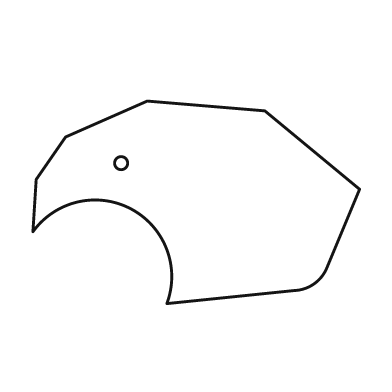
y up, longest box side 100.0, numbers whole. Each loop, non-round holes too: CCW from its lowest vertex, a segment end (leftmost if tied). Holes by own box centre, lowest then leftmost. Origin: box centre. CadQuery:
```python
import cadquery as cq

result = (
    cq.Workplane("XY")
    .moveTo(-9.0, -31.0)
    .lineTo(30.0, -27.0)
    .threePointArc((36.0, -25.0), (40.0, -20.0))
    .lineTo(50.0, 4.0)
    .lineTo(21.0, 28.0)
    .lineTo(-15.0, 31.0)
    .lineTo(-40.0, 20.0)
    .lineTo(-49.0, 7.0)
    .lineTo(-50.0, -9.0)
    .threePointArc((-20.0, -2.0), (-9.0, -31.0))
    .close()
    .moveTo(-23.0, 12.0)
    .circle(2.0)
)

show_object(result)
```